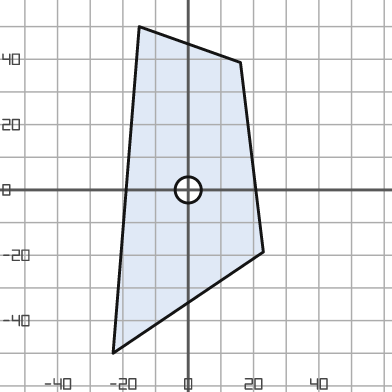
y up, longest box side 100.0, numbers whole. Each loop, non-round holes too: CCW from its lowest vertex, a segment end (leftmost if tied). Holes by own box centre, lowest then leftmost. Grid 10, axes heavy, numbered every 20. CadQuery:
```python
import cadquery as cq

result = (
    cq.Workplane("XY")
    .moveTo(-23.0, -50.0)
    .lineTo(23.0, -19.0)
    .lineTo(16.0, 39.0)
    .lineTo(-15.0, 50.0)
    .close()
    .moveTo(0.0, 0.0)
    .circle(4.0)
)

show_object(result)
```